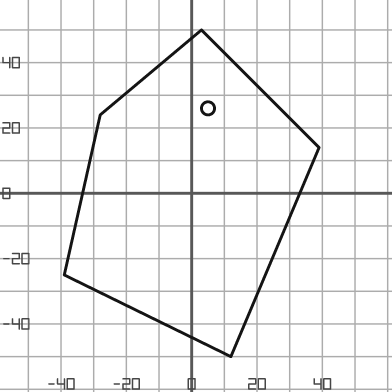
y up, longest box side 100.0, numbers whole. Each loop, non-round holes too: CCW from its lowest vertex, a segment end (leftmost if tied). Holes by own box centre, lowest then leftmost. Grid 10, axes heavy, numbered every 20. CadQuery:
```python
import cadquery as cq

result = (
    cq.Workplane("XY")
    .moveTo(12.0, -50.0)
    .lineTo(39.0, 14.0)
    .lineTo(3.0, 50.0)
    .lineTo(-28.0, 24.0)
    .lineTo(-39.0, -25.0)
    .close()
    .moveTo(5.0, 26.0)
    .circle(2.0)
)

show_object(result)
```